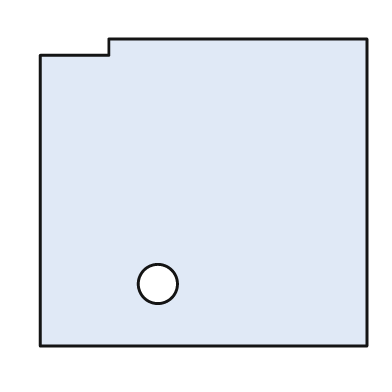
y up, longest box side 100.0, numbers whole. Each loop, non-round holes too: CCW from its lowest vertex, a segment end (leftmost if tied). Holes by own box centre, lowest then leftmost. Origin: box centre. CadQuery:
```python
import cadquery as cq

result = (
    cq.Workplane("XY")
    .moveTo(-50.0, -47.0)
    .lineTo(50.0, -47.0)
    .lineTo(50.0, 47.0)
    .lineTo(-29.0, 47.0)
    .lineTo(-29.0, 42.0)
    .lineTo(-50.0, 42.0)
    .close()
    .moveTo(-14.0, -28.0)
    .circle(6.0)
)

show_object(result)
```